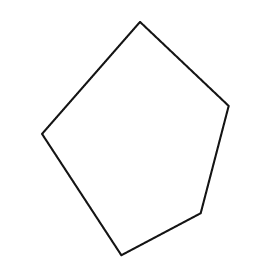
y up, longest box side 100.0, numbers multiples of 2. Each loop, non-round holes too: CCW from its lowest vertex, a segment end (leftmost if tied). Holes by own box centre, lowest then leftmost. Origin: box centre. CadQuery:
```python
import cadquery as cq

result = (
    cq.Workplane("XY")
    .moveTo(-6.0, -50.0)
    .lineTo(28.0, -32.0)
    .lineTo(40.0, 14.0)
    .lineTo(2.0, 50.0)
    .lineTo(-40.0, 2.0)
    .close()
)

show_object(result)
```